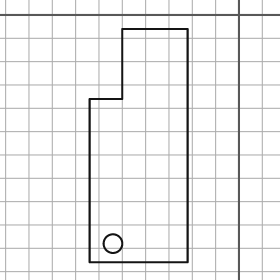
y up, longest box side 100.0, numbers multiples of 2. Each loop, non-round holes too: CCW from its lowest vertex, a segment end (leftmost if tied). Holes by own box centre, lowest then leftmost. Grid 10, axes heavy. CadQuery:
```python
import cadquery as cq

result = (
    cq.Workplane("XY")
    .moveTo(-64.0, -106.0)
    .lineTo(-22.0, -106.0)
    .lineTo(-22.0, -6.0)
    .lineTo(-50.0, -6.0)
    .lineTo(-50.0, -36.0)
    .lineTo(-64.0, -36.0)
    .close()
    .moveTo(-54.0, -98.0)
    .circle(4.0)
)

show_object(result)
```